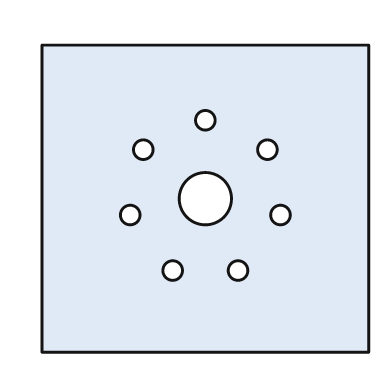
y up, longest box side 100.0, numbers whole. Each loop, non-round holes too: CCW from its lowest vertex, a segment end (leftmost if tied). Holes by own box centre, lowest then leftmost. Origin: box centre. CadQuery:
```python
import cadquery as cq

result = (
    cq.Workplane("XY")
    .moveTo(-50.0, -47.0)
    .lineTo(50.0, -47.0)
    .lineTo(50.0, 47.0)
    .lineTo(-50.0, 47.0)
    .close()
    .moveTo(-10.0, -22.0)
    .circle(3.0)
    .moveTo(10.0, -22.0)
    .circle(3.0)
    .moveTo(-23.0, -5.0)
    .circle(3.0)
    .moveTo(23.0, -5.0)
    .circle(3.0)
    .moveTo(0.0, 0.0)
    .circle(8.0)
    .moveTo(-19.0, 15.0)
    .circle(3.0)
    .moveTo(19.0, 15.0)
    .circle(3.0)
    .moveTo(0.0, 24.0)
    .circle(3.0)
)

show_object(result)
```